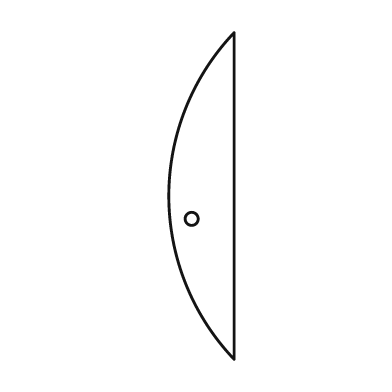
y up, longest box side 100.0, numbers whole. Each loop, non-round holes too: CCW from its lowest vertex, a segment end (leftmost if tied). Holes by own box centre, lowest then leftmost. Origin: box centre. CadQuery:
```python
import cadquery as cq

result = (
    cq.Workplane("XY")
    .moveTo(10.0, -50.0)
    .lineTo(10.0, 50.0)
    .threePointArc((-10.0, 0.0), (10.0, -50.0))
    .close()
    .moveTo(-3.0, -7.0)
    .circle(2.0)
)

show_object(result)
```